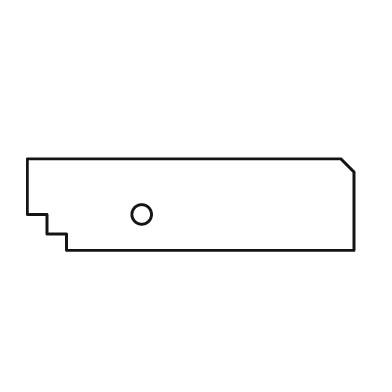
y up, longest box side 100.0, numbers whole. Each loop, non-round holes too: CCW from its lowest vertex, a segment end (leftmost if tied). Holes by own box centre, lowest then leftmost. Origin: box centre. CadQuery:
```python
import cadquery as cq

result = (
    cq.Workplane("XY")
    .moveTo(-38.0, -14.0)
    .lineTo(50.0, -14.0)
    .lineTo(50.0, 10.0)
    .lineTo(46.0, 14.0)
    .lineTo(-50.0, 14.0)
    .lineTo(-50.0, -3.0)
    .lineTo(-44.0, -3.0)
    .lineTo(-44.0, -9.0)
    .lineTo(-38.0, -9.0)
    .close()
    .moveTo(-15.0, -3.0)
    .circle(3.0)
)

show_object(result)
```